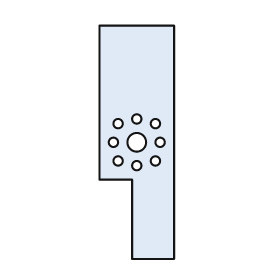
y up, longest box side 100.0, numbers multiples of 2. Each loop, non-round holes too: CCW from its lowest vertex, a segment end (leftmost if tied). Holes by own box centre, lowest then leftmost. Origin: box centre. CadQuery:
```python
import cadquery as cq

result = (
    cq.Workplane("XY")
    .moveTo(-2.0, -50.0)
    .lineTo(16.0, -50.0)
    .lineTo(16.0, 50.0)
    .lineTo(-16.0, 50.0)
    .lineTo(-16.0, -16.0)
    .lineTo(-2.0, -16.0)
    .close()
    .moveTo(0.0, -10.0)
    .circle(2.0)
    .moveTo(-8.0, -8.0)
    .circle(2.0)
    .moveTo(8.0, -8.0)
    .circle(2.0)
    .moveTo(-10.0, 0.0)
    .circle(2.0)
    .moveTo(0.0, 0.0)
    .circle(4.0)
    .moveTo(10.0, 0.0)
    .circle(2.0)
    .moveTo(-8.0, 8.0)
    .circle(2.0)
    .moveTo(8.0, 8.0)
    .circle(2.0)
    .moveTo(0.0, 10.0)
    .circle(2.0)
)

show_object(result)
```